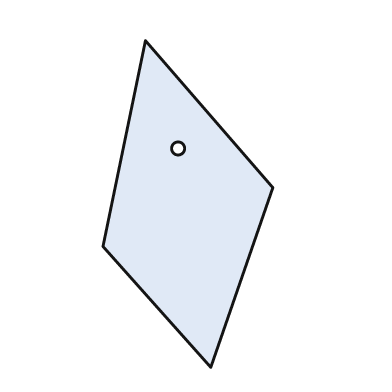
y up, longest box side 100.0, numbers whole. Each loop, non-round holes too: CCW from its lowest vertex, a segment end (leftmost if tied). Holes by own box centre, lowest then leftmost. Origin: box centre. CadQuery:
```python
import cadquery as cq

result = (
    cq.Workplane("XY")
    .moveTo(7.0, -50.0)
    .lineTo(26.0, 5.0)
    .lineTo(-13.0, 50.0)
    .lineTo(-26.0, -13.0)
    .close()
    .moveTo(-3.0, 17.0)
    .circle(2.0)
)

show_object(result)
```